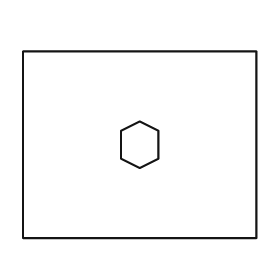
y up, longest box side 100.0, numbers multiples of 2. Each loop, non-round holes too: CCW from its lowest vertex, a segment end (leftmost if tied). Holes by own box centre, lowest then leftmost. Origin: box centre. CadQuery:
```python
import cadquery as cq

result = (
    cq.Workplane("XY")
    .moveTo(-50.0, -40.0)
    .lineTo(50.0, -40.0)
    .lineTo(50.0, 40.0)
    .lineTo(-50.0, 40.0)
    .close()
    .moveTo(0.0, -10.0)
    .lineTo(8.0, -6.0)
    .lineTo(8.0, 6.0)
    .lineTo(0.0, 10.0)
    .lineTo(-8.0, 6.0)
    .lineTo(-8.0, -6.0)
    .close()
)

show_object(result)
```